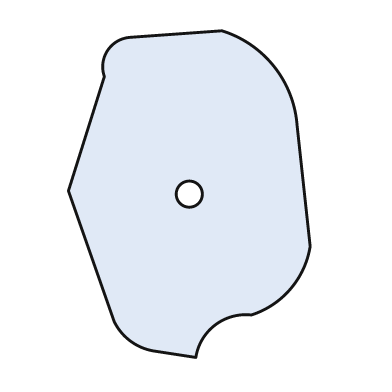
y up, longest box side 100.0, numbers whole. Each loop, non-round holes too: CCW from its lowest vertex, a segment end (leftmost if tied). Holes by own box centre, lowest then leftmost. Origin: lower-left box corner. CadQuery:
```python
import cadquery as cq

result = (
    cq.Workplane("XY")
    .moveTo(39.0, 0.0)
    .threePointArc((45.0, 10.0), (56.0, 13.0))
    .threePointArc((68.0, 21.0), (74.0, 34.0))
    .lineTo(70.0, 71.0)
    .threePointArc((63.0, 89.0), (47.0, 100.0))
    .lineTo(19.0, 98.0)
    .threePointArc((12.0, 94.0), (11.0, 86.0))
    .lineTo(0.0, 51.0)
    .lineTo(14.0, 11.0)
    .threePointArc((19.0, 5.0), (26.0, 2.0))
    .close()
    .moveTo(37.0, 50.0)
    .circle(4.0)
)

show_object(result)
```